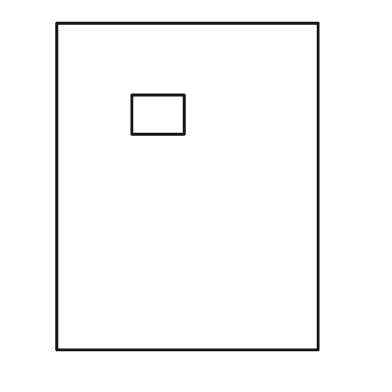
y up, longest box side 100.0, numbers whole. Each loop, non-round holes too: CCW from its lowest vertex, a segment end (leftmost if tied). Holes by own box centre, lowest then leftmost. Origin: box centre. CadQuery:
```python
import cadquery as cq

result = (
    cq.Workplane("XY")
    .moveTo(-40.0, -50.0)
    .lineTo(40.0, -50.0)
    .lineTo(40.0, 50.0)
    .lineTo(-40.0, 50.0)
    .close()
    .moveTo(-17.0, 16.0)
    .lineTo(-1.0, 16.0)
    .lineTo(-1.0, 28.0)
    .lineTo(-17.0, 28.0)
    .close()
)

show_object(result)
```